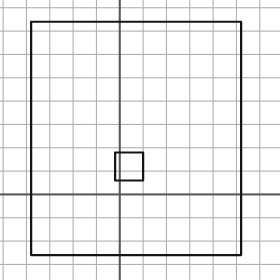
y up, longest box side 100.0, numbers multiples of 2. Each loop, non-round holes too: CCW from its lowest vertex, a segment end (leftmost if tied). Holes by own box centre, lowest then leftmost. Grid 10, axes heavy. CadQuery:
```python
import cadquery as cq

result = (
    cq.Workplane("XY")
    .moveTo(-38.0, -26.0)
    .lineTo(52.0, -26.0)
    .lineTo(52.0, 74.0)
    .lineTo(-38.0, 74.0)
    .close()
    .moveTo(-2.0, 6.0)
    .lineTo(10.0, 6.0)
    .lineTo(10.0, 18.0)
    .lineTo(-2.0, 18.0)
    .close()
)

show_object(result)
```